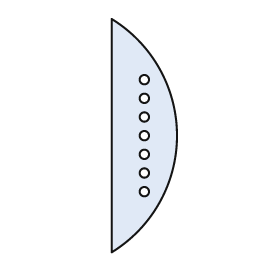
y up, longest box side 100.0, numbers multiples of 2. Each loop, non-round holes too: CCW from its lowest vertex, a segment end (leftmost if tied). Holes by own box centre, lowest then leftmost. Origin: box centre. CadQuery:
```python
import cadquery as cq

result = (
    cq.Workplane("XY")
    .moveTo(-14.0, -50.0)
    .threePointArc((14.0, 0.0), (-14.0, 50.0))
    .close()
    .moveTo(0.0, -24.0)
    .circle(2.0)
    .moveTo(0.0, -16.0)
    .circle(2.0)
    .moveTo(0.0, -8.0)
    .circle(2.0)
    .moveTo(0.0, 0.0)
    .circle(2.0)
    .moveTo(0.0, 8.0)
    .circle(2.0)
    .moveTo(0.0, 16.0)
    .circle(2.0)
    .moveTo(0.0, 24.0)
    .circle(2.0)
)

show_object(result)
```